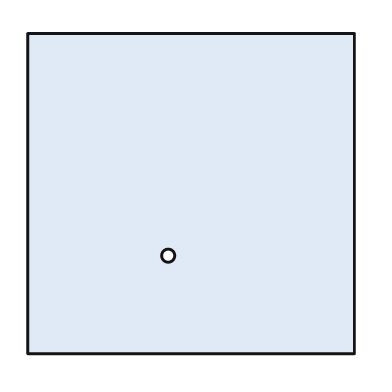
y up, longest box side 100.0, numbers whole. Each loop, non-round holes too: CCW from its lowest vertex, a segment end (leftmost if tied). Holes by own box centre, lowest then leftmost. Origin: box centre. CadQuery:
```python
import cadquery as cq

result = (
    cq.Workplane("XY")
    .moveTo(-50.0, -49.0)
    .lineTo(50.0, -49.0)
    .lineTo(50.0, 49.0)
    .lineTo(-50.0, 49.0)
    .close()
    .moveTo(-7.0, -19.0)
    .circle(2.0)
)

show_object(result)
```